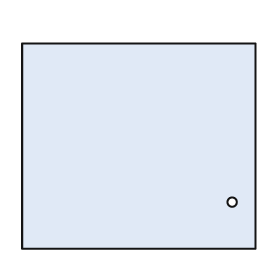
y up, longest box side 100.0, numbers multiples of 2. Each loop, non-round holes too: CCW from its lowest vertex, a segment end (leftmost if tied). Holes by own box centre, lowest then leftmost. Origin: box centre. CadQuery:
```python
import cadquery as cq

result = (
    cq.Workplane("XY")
    .moveTo(-50.0, -44.0)
    .lineTo(50.0, -44.0)
    .lineTo(50.0, 44.0)
    .lineTo(-50.0, 44.0)
    .close()
    .moveTo(40.0, -24.0)
    .circle(2.0)
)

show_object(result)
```